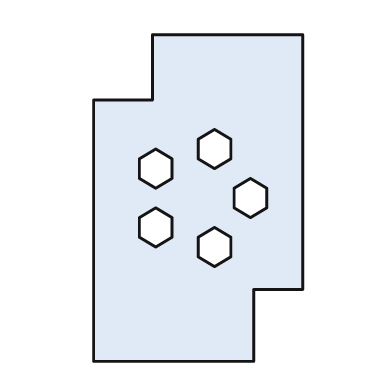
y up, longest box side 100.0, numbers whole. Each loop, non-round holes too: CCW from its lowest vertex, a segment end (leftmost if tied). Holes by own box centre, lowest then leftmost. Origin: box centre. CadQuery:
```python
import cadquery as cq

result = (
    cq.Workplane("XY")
    .moveTo(-32.0, -50.0)
    .lineTo(17.0, -50.0)
    .lineTo(17.0, -28.0)
    .lineTo(32.0, -28.0)
    .lineTo(32.0, 50.0)
    .lineTo(-14.0, 50.0)
    .lineTo(-14.0, 30.0)
    .lineTo(-32.0, 30.0)
    .close()
    .moveTo(5.0, -21.0)
    .lineTo(10.0, -18.0)
    .lineTo(10.0, -12.0)
    .lineTo(5.0, -9.0)
    .lineTo(0.0, -12.0)
    .lineTo(0.0, -18.0)
    .close()
    .moveTo(-13.0, -15.0)
    .lineTo(-8.0, -12.0)
    .lineTo(-8.0, -6.0)
    .lineTo(-13.0, -3.0)
    .lineTo(-18.0, -6.0)
    .lineTo(-18.0, -12.0)
    .close()
    .moveTo(16.0, -6.0)
    .lineTo(21.0, -3.0)
    .lineTo(21.0, 3.0)
    .lineTo(16.0, 6.0)
    .lineTo(11.0, 3.0)
    .lineTo(11.0, -3.0)
    .close()
    .moveTo(-13.0, 3.0)
    .lineTo(-8.0, 6.0)
    .lineTo(-8.0, 12.0)
    .lineTo(-13.0, 15.0)
    .lineTo(-18.0, 12.0)
    .lineTo(-18.0, 6.0)
    .close()
    .moveTo(5.0, 9.0)
    .lineTo(10.0, 12.0)
    .lineTo(10.0, 18.0)
    .lineTo(5.0, 21.0)
    .lineTo(0.0, 18.0)
    .lineTo(0.0, 12.0)
    .close()
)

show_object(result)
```